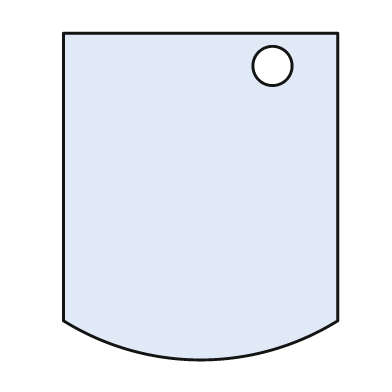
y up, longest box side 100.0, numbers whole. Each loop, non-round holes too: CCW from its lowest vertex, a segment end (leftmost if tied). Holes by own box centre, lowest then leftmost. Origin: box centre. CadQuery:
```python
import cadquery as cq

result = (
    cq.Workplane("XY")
    .moveTo(-42.0, -38.0)
    .threePointArc((0.0, -50.0), (42.0, -38.0))
    .lineTo(42.0, 50.0)
    .lineTo(-42.0, 50.0)
    .close()
    .moveTo(22.0, 40.0)
    .circle(6.0)
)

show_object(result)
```